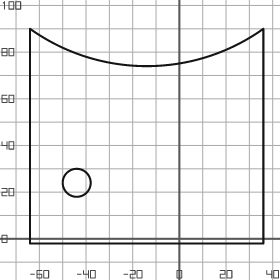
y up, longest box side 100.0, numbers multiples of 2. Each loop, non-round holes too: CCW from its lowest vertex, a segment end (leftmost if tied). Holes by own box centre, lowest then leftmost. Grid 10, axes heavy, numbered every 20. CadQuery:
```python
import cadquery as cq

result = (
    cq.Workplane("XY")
    .moveTo(-64.0, -2.0)
    .lineTo(36.0, -2.0)
    .lineTo(36.0, 90.0)
    .threePointArc((-14.0, 74.0), (-64.0, 90.0))
    .close()
    .moveTo(-44.0, 24.0)
    .circle(6.0)
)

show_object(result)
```